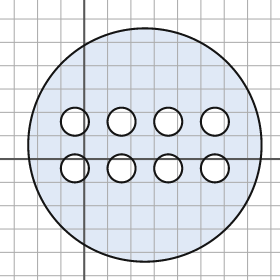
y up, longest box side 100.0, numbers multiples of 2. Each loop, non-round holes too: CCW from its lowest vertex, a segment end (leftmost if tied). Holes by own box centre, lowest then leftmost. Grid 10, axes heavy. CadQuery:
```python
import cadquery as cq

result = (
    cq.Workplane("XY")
    .moveTo(26.0, 6.0)
    .circle(50.0)
    .moveTo(-4.0, -4.0)
    .circle(6.0)
    .moveTo(16.0, -4.0)
    .circle(6.0)
    .moveTo(36.0, -4.0)
    .circle(6.0)
    .moveTo(56.0, -4.0)
    .circle(6.0)
    .moveTo(-4.0, 16.0)
    .circle(6.0)
    .moveTo(16.0, 16.0)
    .circle(6.0)
    .moveTo(36.0, 16.0)
    .circle(6.0)
    .moveTo(56.0, 16.0)
    .circle(6.0)
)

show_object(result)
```